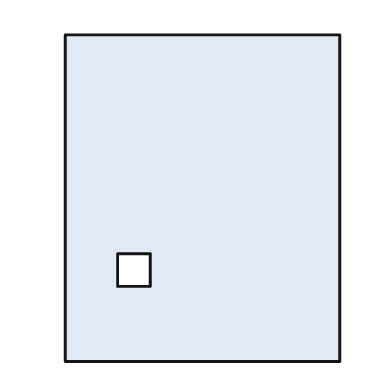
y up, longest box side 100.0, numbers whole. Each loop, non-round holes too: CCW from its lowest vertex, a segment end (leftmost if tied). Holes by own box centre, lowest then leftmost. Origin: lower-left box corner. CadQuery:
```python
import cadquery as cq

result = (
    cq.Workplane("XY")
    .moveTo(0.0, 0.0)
    .lineTo(84.0, 0.0)
    .lineTo(84.0, 100.0)
    .lineTo(0.0, 100.0)
    .close()
    .moveTo(16.0, 23.0)
    .lineTo(26.0, 23.0)
    .lineTo(26.0, 33.0)
    .lineTo(16.0, 33.0)
    .close()
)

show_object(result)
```